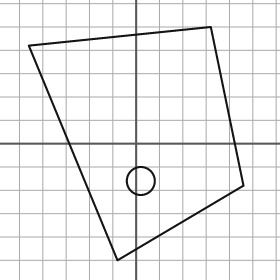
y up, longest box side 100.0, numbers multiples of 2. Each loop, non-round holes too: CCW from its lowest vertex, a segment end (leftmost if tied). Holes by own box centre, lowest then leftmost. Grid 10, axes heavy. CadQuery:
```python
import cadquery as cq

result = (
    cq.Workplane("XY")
    .moveTo(-8.0, -50.0)
    .lineTo(46.0, -18.0)
    .lineTo(32.0, 50.0)
    .lineTo(-46.0, 42.0)
    .close()
    .moveTo(2.0, -16.0)
    .circle(6.0)
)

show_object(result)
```